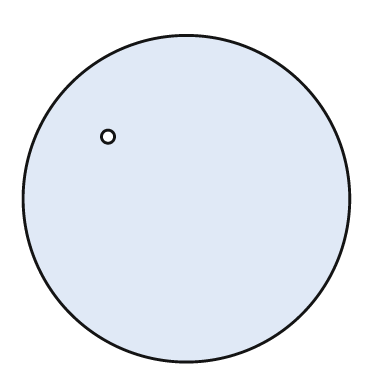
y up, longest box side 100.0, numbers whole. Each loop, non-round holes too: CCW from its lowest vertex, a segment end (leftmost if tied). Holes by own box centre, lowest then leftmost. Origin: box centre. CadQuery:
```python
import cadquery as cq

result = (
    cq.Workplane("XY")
    .moveTo(0.0, 0.0)
    .circle(50.0)
    .moveTo(-24.0, 19.0)
    .circle(2.0)
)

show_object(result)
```